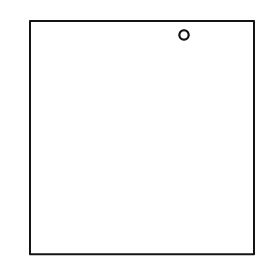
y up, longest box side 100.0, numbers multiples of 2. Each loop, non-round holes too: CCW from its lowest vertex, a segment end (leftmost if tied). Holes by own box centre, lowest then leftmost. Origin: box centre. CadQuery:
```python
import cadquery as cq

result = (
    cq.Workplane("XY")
    .moveTo(-48.0, -50.0)
    .lineTo(48.0, -50.0)
    .lineTo(48.0, 50.0)
    .lineTo(-48.0, 50.0)
    .close()
    .moveTo(18.0, 44.0)
    .circle(2.0)
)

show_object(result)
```